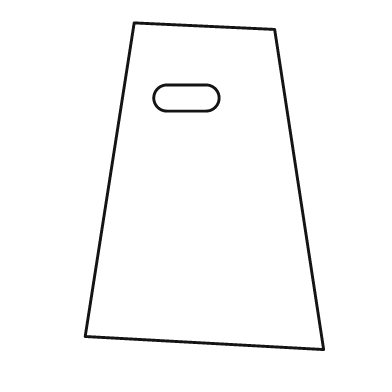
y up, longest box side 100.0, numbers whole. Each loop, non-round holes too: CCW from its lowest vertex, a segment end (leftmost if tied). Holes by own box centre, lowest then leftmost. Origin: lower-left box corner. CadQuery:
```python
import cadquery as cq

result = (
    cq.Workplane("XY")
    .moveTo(73.0, 0.0)
    .lineTo(58.0, 98.0)
    .lineTo(15.0, 100.0)
    .lineTo(0.0, 4.0)
    .close()
    .moveTo(25.0, 73.0)
    .lineTo(37.0, 73.0)
    .threePointArc((41.0, 77.0), (37.0, 81.0))
    .lineTo(25.0, 81.0)
    .threePointArc((21.0, 77.0), (25.0, 73.0))
    .close()
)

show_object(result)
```